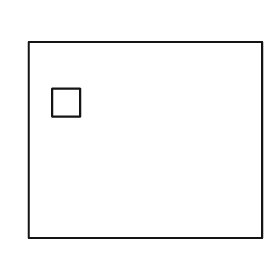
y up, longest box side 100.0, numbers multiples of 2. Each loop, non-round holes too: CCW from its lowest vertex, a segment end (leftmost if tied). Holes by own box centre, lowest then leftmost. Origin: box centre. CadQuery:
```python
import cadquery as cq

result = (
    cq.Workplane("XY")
    .moveTo(-50.0, -42.0)
    .lineTo(50.0, -42.0)
    .lineTo(50.0, 42.0)
    .lineTo(-50.0, 42.0)
    .close()
    .moveTo(-40.0, 10.0)
    .lineTo(-28.0, 10.0)
    .lineTo(-28.0, 22.0)
    .lineTo(-40.0, 22.0)
    .close()
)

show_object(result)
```